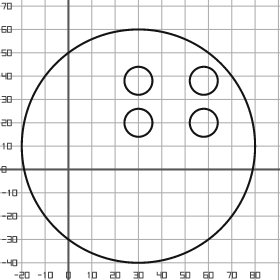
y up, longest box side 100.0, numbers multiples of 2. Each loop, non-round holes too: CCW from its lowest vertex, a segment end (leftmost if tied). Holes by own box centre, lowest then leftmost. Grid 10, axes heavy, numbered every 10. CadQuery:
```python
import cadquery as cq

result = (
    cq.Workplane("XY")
    .moveTo(30.0, 10.0)
    .circle(50.0)
    .moveTo(30.0, 20.0)
    .circle(6.0)
    .moveTo(58.0, 20.0)
    .circle(6.0)
    .moveTo(30.0, 38.0)
    .circle(6.0)
    .moveTo(58.0, 38.0)
    .circle(6.0)
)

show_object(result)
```